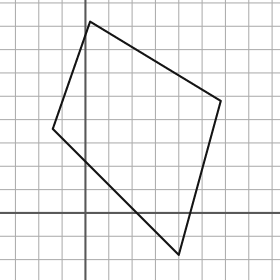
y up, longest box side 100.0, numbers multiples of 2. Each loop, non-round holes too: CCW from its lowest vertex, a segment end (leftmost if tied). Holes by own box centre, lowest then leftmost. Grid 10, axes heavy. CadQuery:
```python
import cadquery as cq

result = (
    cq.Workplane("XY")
    .moveTo(40.0, -18.0)
    .lineTo(58.0, 48.0)
    .lineTo(2.0, 82.0)
    .lineTo(-14.0, 36.0)
    .close()
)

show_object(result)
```